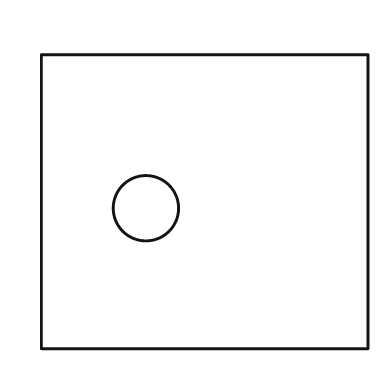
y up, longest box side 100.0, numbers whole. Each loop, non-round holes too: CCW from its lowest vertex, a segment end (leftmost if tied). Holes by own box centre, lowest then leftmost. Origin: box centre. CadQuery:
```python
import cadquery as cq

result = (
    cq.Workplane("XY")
    .moveTo(-50.0, -45.0)
    .lineTo(50.0, -45.0)
    .lineTo(50.0, 45.0)
    .lineTo(-50.0, 45.0)
    .close()
    .moveTo(-18.0, -2.0)
    .circle(10.0)
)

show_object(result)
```